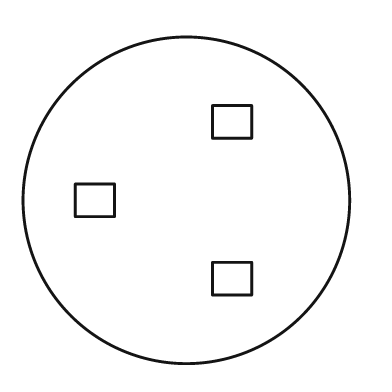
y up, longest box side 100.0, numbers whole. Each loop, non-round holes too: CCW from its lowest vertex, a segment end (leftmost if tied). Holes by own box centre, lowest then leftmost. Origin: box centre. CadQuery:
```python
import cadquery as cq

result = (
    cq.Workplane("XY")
    .moveTo(0.0, 0.0)
    .circle(50.0)
    .moveTo(8.0, -29.0)
    .lineTo(20.0, -29.0)
    .lineTo(20.0, -19.0)
    .lineTo(8.0, -19.0)
    .close()
    .moveTo(-34.0, -5.0)
    .lineTo(-22.0, -5.0)
    .lineTo(-22.0, 5.0)
    .lineTo(-34.0, 5.0)
    .close()
    .moveTo(8.0, 19.0)
    .lineTo(20.0, 19.0)
    .lineTo(20.0, 29.0)
    .lineTo(8.0, 29.0)
    .close()
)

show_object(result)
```